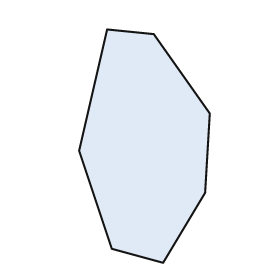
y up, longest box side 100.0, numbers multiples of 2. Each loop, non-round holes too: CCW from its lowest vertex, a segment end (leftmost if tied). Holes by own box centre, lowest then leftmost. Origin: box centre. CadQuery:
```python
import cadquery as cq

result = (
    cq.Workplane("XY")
    .moveTo(8.0, -50.0)
    .lineTo(26.0, -20.0)
    .lineTo(28.0, 14.0)
    .lineTo(4.0, 48.0)
    .lineTo(-16.0, 50.0)
    .lineTo(-28.0, -2.0)
    .lineTo(-14.0, -44.0)
    .close()
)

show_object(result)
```